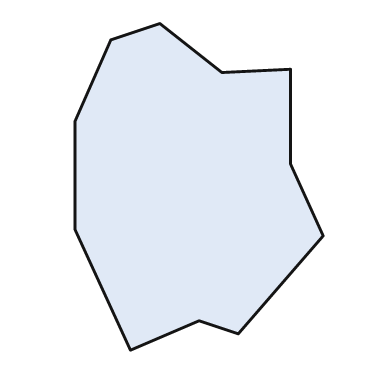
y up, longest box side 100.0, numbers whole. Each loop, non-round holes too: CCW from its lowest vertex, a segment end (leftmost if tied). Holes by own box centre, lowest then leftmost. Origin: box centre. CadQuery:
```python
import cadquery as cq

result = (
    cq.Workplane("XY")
    .moveTo(-21.0, -50.0)
    .lineTo(0.0, -41.0)
    .lineTo(12.0, -45.0)
    .lineTo(38.0, -15.0)
    .lineTo(28.0, 7.0)
    .lineTo(28.0, 36.0)
    .lineTo(7.0, 35.0)
    .lineTo(-12.0, 50.0)
    .lineTo(-27.0, 45.0)
    .lineTo(-38.0, 20.0)
    .lineTo(-38.0, -13.0)
    .close()
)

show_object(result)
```